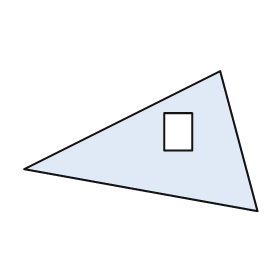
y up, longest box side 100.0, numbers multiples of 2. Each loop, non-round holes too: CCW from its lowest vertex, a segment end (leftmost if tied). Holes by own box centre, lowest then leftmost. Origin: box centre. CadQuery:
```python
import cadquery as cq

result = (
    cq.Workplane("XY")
    .moveTo(50.0, -30.0)
    .lineTo(34.0, 30.0)
    .lineTo(-50.0, -12.0)
    .close()
    .moveTo(10.0, -4.0)
    .lineTo(22.0, -4.0)
    .lineTo(22.0, 12.0)
    .lineTo(10.0, 12.0)
    .close()
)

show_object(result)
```